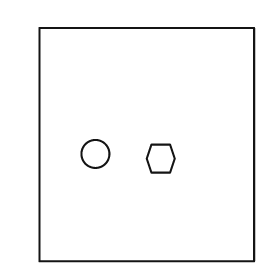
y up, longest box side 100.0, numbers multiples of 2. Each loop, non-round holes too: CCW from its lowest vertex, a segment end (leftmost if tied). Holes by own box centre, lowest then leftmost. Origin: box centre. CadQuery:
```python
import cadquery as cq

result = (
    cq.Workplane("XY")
    .moveTo(-46.0, -50.0)
    .lineTo(46.0, -50.0)
    .lineTo(46.0, 50.0)
    .lineTo(-46.0, 50.0)
    .close()
    .moveTo(2.0, -12.0)
    .lineTo(10.0, -12.0)
    .lineTo(12.0, -6.0)
    .lineTo(10.0, 0.0)
    .lineTo(2.0, 0.0)
    .lineTo(0.0, -6.0)
    .close()
    .moveTo(-22.0, -4.0)
    .circle(6.0)
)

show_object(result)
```